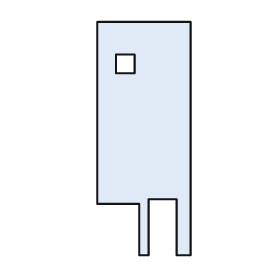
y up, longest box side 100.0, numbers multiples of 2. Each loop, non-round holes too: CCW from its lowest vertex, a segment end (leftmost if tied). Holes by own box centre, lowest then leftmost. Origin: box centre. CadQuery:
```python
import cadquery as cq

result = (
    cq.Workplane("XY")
    .moveTo(-2.0, -50.0)
    .lineTo(2.0, -50.0)
    .lineTo(2.0, -26.0)
    .lineTo(14.0, -26.0)
    .lineTo(14.0, -50.0)
    .lineTo(20.0, -50.0)
    .lineTo(20.0, 50.0)
    .lineTo(-20.0, 50.0)
    .lineTo(-20.0, -28.0)
    .lineTo(-2.0, -28.0)
    .close()
    .moveTo(-12.0, 28.0)
    .lineTo(-4.0, 28.0)
    .lineTo(-4.0, 36.0)
    .lineTo(-12.0, 36.0)
    .close()
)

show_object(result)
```